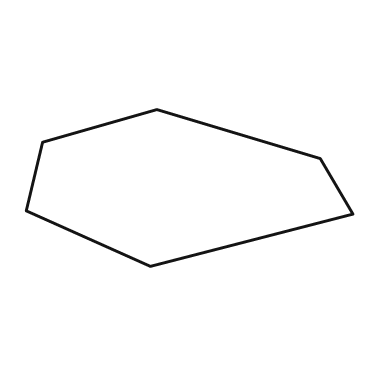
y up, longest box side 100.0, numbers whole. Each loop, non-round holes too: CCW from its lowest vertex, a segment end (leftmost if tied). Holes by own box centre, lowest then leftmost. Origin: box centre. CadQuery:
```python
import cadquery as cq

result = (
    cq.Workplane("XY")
    .moveTo(-12.0, -24.0)
    .lineTo(50.0, -8.0)
    .lineTo(40.0, 9.0)
    .lineTo(-10.0, 24.0)
    .lineTo(-45.0, 14.0)
    .lineTo(-50.0, -7.0)
    .close()
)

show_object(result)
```